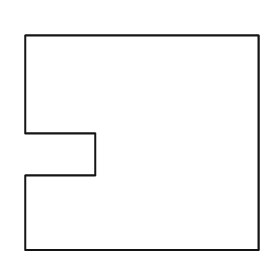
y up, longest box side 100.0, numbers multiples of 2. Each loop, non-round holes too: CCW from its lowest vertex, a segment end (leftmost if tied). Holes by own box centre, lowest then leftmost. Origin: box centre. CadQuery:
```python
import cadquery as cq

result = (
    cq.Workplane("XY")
    .moveTo(-50.0, -46.0)
    .lineTo(50.0, -46.0)
    .lineTo(50.0, 46.0)
    .lineTo(-50.0, 46.0)
    .lineTo(-50.0, 4.0)
    .lineTo(-20.0, 4.0)
    .lineTo(-20.0, -14.0)
    .lineTo(-50.0, -14.0)
    .close()
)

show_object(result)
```